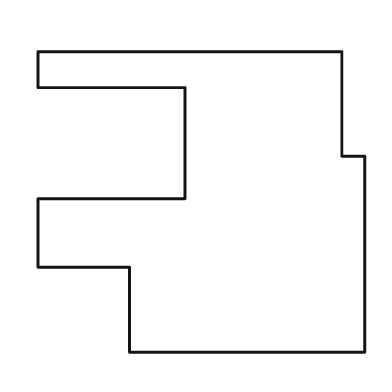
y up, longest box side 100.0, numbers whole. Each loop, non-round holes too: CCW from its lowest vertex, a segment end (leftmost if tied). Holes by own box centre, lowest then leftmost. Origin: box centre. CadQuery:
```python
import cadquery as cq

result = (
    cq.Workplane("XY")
    .moveTo(-22.0, -46.0)
    .lineTo(50.0, -46.0)
    .lineTo(50.0, 14.0)
    .lineTo(43.0, 14.0)
    .lineTo(43.0, 46.0)
    .lineTo(-50.0, 46.0)
    .lineTo(-50.0, 35.0)
    .lineTo(-5.0, 35.0)
    .lineTo(-5.0, 1.0)
    .lineTo(-50.0, 1.0)
    .lineTo(-50.0, -20.0)
    .lineTo(-22.0, -20.0)
    .close()
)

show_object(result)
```